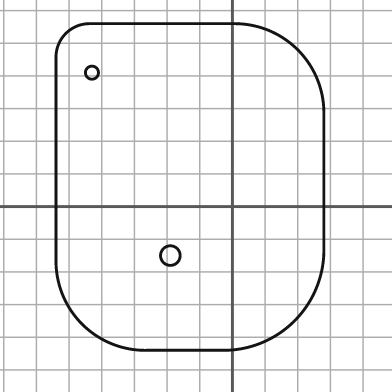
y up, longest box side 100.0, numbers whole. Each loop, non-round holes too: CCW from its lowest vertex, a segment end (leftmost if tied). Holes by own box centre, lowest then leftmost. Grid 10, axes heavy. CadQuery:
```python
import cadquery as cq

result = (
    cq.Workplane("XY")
    .moveTo(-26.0, -44.0)
    .lineTo(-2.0, -44.0)
    .threePointArc((19.0, -35.0), (28.0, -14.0))
    .lineTo(28.0, 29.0)
    .threePointArc((20.0, 48.0), (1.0, 56.0))
    .lineTo(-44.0, 56.0)
    .threePointArc((-51.0, 53.0), (-54.0, 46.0))
    .lineTo(-54.0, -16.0)
    .threePointArc((-46.0, -36.0), (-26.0, -44.0))
    .close()
    .moveTo(-19.0, -15.0)
    .circle(3.0)
    .moveTo(-43.0, 41.0)
    .circle(2.0)
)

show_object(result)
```